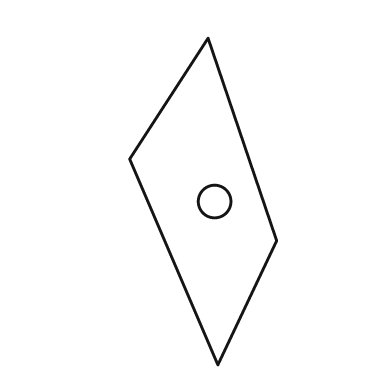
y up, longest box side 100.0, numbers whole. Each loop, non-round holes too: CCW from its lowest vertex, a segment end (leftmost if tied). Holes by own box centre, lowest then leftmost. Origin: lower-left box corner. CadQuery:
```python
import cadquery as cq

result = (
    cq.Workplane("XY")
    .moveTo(27.0, 0.0)
    .lineTo(45.0, 38.0)
    .lineTo(24.0, 100.0)
    .lineTo(0.0, 63.0)
    .close()
    .moveTo(26.0, 50.0)
    .circle(5.0)
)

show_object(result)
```